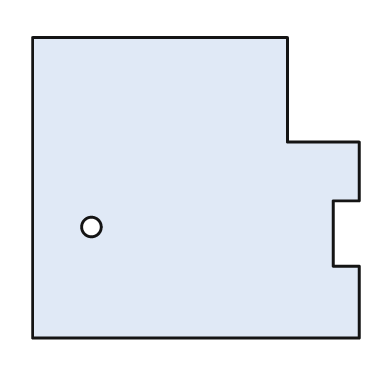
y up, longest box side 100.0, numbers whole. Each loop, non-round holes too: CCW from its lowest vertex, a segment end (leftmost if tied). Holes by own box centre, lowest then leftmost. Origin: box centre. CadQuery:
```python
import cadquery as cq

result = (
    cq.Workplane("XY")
    .moveTo(-50.0, -46.0)
    .lineTo(50.0, -46.0)
    .lineTo(50.0, -24.0)
    .lineTo(42.0, -24.0)
    .lineTo(42.0, -4.0)
    .lineTo(50.0, -4.0)
    .lineTo(50.0, 14.0)
    .lineTo(28.0, 14.0)
    .lineTo(28.0, 46.0)
    .lineTo(-50.0, 46.0)
    .close()
    .moveTo(-32.0, -12.0)
    .circle(3.0)
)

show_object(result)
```